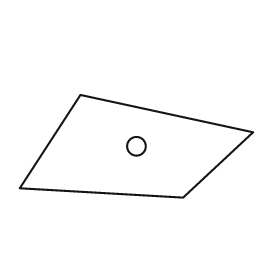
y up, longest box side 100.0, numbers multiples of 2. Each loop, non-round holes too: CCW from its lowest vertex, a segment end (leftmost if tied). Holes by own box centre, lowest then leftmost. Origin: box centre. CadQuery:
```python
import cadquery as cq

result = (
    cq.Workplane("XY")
    .moveTo(20.0, -22.0)
    .lineTo(50.0, 6.0)
    .lineTo(-24.0, 22.0)
    .lineTo(-50.0, -18.0)
    .close()
    .moveTo(0.0, 0.0)
    .circle(4.0)
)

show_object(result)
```